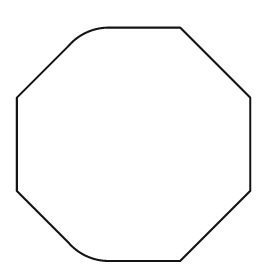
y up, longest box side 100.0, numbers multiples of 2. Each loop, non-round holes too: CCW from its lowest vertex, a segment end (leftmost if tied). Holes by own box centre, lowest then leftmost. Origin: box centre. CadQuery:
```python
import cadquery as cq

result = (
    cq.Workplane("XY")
    .moveTo(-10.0, -50.0)
    .lineTo(20.0, -50.0)
    .lineTo(50.0, -20.0)
    .lineTo(50.0, 20.0)
    .lineTo(20.0, 50.0)
    .lineTo(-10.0, 50.0)
    .threePointArc((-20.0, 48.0), (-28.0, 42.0))
    .lineTo(-50.0, 20.0)
    .lineTo(-50.0, -20.0)
    .lineTo(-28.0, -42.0)
    .threePointArc((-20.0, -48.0), (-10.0, -50.0))
    .close()
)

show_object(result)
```